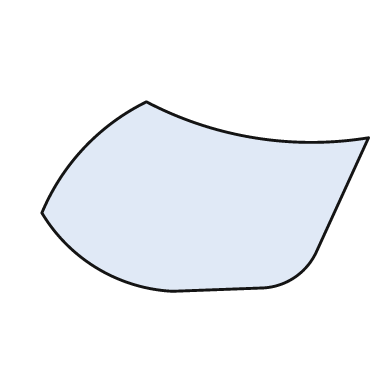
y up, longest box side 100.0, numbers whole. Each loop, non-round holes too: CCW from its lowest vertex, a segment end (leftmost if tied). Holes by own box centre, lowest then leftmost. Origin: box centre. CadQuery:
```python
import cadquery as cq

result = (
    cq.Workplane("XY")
    .moveTo(-10.0, -29.0)
    .lineTo(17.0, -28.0)
    .threePointArc((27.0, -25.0), (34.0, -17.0))
    .lineTo(50.0, 18.0)
    .threePointArc((15.0, 18.0), (-18.0, 29.0))
    .threePointArc((-37.0, 15.0), (-50.0, -5.0))
    .threePointArc((-33.0, -22.0), (-10.0, -29.0))
    .close()
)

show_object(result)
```